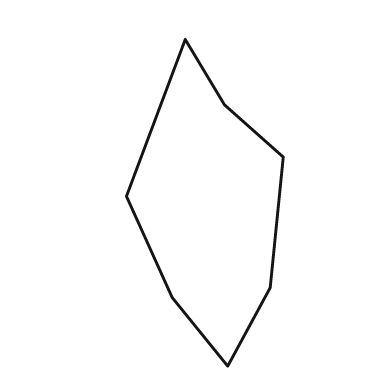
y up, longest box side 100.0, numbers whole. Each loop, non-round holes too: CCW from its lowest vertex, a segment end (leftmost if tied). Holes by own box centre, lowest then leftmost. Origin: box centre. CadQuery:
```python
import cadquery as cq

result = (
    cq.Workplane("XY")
    .moveTo(7.0, -50.0)
    .lineTo(20.0, -26.0)
    .lineTo(24.0, 14.0)
    .lineTo(6.0, 30.0)
    .lineTo(-6.0, 50.0)
    .lineTo(-24.0, 2.0)
    .lineTo(-10.0, -29.0)
    .close()
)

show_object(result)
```